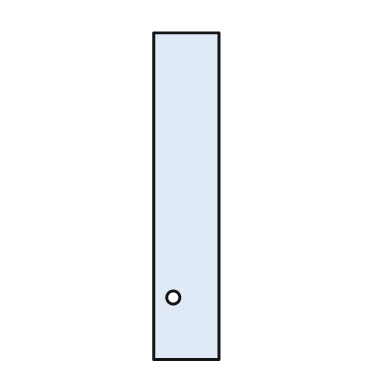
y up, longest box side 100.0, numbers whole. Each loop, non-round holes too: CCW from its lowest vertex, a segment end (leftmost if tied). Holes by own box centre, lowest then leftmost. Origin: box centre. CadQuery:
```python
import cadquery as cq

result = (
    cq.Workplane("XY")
    .moveTo(-10.0, -50.0)
    .lineTo(10.0, -50.0)
    .lineTo(10.0, 50.0)
    .lineTo(-10.0, 50.0)
    .close()
    .moveTo(-4.0, -31.0)
    .circle(2.0)
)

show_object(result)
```